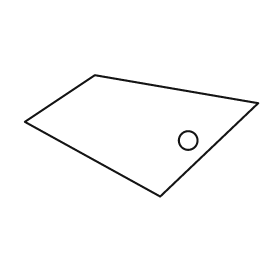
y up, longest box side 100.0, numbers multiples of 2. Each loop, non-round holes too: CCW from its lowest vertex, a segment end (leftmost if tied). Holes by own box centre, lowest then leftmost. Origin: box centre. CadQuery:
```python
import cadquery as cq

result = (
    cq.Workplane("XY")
    .moveTo(8.0, -26.0)
    .lineTo(50.0, 14.0)
    .lineTo(-20.0, 26.0)
    .lineTo(-50.0, 6.0)
    .close()
    .moveTo(20.0, -2.0)
    .circle(4.0)
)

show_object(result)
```